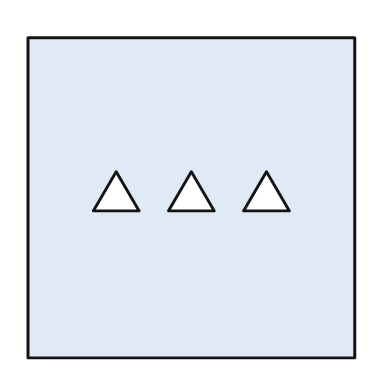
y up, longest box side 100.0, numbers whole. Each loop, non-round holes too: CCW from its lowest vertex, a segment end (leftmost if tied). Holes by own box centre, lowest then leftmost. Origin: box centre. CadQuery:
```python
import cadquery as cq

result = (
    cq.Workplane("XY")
    .moveTo(-50.0, -49.0)
    .lineTo(50.0, -49.0)
    .lineTo(50.0, 49.0)
    .lineTo(-50.0, 49.0)
    .close()
    .moveTo(-30.0, -4.0)
    .lineTo(-16.0, -4.0)
    .lineTo(-23.0, 8.0)
    .close()
    .moveTo(-7.0, -4.0)
    .lineTo(7.0, -4.0)
    .lineTo(0.0, 8.0)
    .close()
    .moveTo(16.0, -4.0)
    .lineTo(30.0, -4.0)
    .lineTo(23.0, 8.0)
    .close()
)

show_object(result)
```